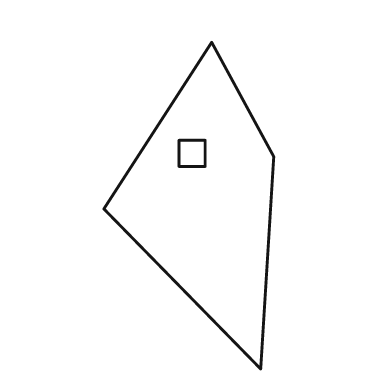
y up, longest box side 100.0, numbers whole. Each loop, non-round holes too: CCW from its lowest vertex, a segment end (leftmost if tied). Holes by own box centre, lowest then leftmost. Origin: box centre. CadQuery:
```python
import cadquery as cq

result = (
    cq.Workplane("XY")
    .moveTo(22.0, -50.0)
    .lineTo(26.0, 15.0)
    .lineTo(7.0, 50.0)
    .lineTo(-26.0, -1.0)
    .close()
    .moveTo(-3.0, 12.0)
    .lineTo(5.0, 12.0)
    .lineTo(5.0, 20.0)
    .lineTo(-3.0, 20.0)
    .close()
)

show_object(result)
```